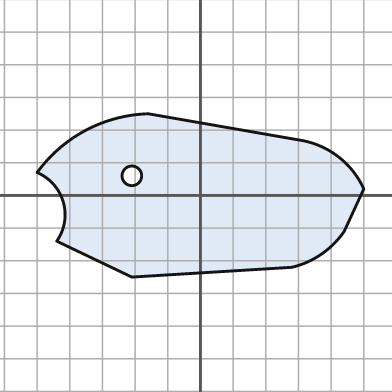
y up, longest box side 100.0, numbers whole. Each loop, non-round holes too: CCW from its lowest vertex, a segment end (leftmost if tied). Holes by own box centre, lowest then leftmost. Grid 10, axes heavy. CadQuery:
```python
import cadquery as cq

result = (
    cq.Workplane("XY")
    .moveTo(-21.0, -25.0)
    .lineTo(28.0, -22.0)
    .threePointArc((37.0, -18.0), (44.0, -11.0))
    .lineTo(50.0, 2.0)
    .threePointArc((42.0, 12.0), (30.0, 17.0))
    .lineTo(-16.0, 25.0)
    .threePointArc((-35.0, 20.0), (-50.0, 7.0))
    .threePointArc((-42.0, -2.0), (-44.0, -14.0))
    .close()
    .moveTo(-21.0, 6.0)
    .circle(3.0)
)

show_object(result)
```